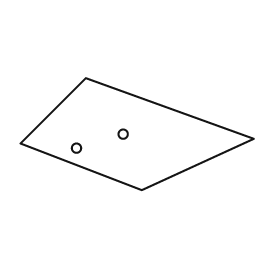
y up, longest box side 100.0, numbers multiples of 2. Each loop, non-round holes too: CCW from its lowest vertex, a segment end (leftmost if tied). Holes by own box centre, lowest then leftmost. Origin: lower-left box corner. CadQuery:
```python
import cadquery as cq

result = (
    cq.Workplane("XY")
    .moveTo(52.0, 0.0)
    .lineTo(100.0, 22.0)
    .lineTo(28.0, 48.0)
    .lineTo(0.0, 20.0)
    .close()
    .moveTo(24.0, 18.0)
    .circle(2.0)
    .moveTo(44.0, 24.0)
    .circle(2.0)
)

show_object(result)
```